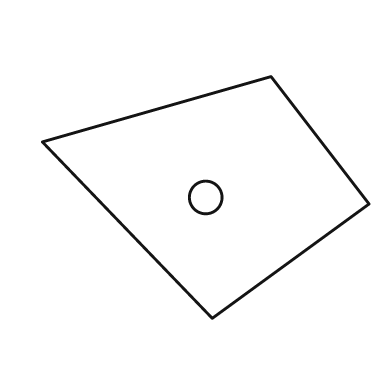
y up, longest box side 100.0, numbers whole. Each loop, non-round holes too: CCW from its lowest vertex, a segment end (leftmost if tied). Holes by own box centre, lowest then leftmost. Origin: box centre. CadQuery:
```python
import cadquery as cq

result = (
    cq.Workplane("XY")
    .moveTo(2.0, -37.0)
    .lineTo(50.0, -2.0)
    .lineTo(20.0, 37.0)
    .lineTo(-50.0, 17.0)
    .close()
    .moveTo(0.0, 0.0)
    .circle(5.0)
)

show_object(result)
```